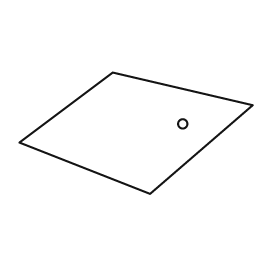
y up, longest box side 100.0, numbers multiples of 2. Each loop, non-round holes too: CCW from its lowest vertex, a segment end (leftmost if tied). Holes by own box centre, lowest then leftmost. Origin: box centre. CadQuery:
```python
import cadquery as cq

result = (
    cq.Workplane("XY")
    .moveTo(6.0, -26.0)
    .lineTo(50.0, 12.0)
    .lineTo(-10.0, 26.0)
    .lineTo(-50.0, -4.0)
    .close()
    .moveTo(20.0, 4.0)
    .circle(2.0)
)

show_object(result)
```